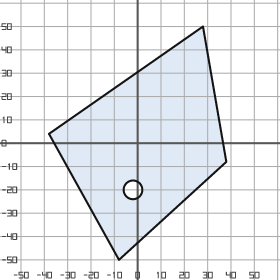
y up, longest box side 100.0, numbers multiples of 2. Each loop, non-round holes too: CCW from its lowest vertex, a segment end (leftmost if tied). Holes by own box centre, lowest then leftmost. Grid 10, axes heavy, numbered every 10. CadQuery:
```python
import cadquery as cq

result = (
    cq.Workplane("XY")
    .moveTo(-8.0, -50.0)
    .lineTo(38.0, -8.0)
    .lineTo(28.0, 50.0)
    .lineTo(-38.0, 4.0)
    .close()
    .moveTo(-2.0, -20.0)
    .circle(4.0)
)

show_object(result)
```